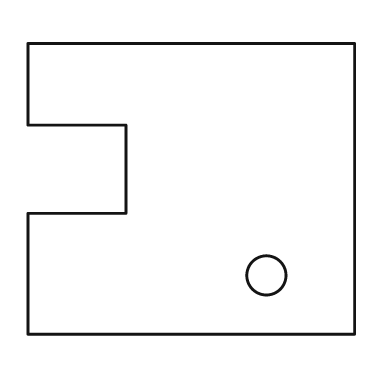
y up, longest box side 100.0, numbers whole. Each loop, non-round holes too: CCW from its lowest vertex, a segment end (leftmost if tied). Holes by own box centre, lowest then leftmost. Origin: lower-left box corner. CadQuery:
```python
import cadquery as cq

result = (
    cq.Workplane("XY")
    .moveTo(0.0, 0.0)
    .lineTo(100.0, 0.0)
    .lineTo(100.0, 89.0)
    .lineTo(0.0, 89.0)
    .lineTo(0.0, 64.0)
    .lineTo(30.0, 64.0)
    .lineTo(30.0, 37.0)
    .lineTo(0.0, 37.0)
    .close()
    .moveTo(73.0, 18.0)
    .circle(6.0)
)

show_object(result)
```